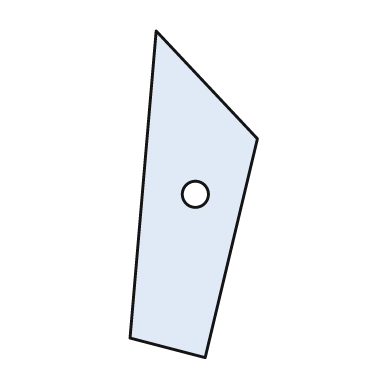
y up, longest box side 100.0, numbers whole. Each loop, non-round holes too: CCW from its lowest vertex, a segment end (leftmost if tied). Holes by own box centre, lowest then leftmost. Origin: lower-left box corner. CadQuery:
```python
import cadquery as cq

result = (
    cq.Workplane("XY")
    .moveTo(23.0, 0.0)
    .lineTo(39.0, 67.0)
    .lineTo(8.0, 100.0)
    .lineTo(0.0, 6.0)
    .close()
    .moveTo(20.0, 50.0)
    .circle(4.0)
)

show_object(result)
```